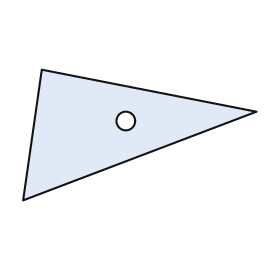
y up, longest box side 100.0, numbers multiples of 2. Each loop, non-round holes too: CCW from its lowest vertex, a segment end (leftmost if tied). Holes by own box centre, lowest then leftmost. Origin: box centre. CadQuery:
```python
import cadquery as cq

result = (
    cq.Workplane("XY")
    .moveTo(-50.0, -28.0)
    .lineTo(50.0, 10.0)
    .lineTo(-42.0, 28.0)
    .close()
    .moveTo(-6.0, 6.0)
    .circle(4.0)
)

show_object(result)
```